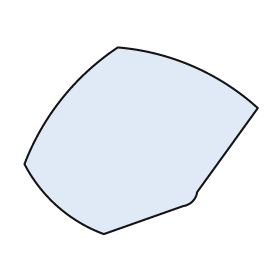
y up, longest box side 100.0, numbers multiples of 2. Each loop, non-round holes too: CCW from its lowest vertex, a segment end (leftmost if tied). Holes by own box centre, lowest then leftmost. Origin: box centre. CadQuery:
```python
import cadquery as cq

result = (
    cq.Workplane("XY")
    .moveTo(-16.0, -40.0)
    .lineTo(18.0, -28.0)
    .threePointArc((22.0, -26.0), (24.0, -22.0))
    .lineTo(50.0, 14.0)
    .threePointArc((22.0, 32.0), (-10.0, 40.0))
    .threePointArc((-34.0, 18.0), (-50.0, -10.0))
    .threePointArc((-36.0, -28.0), (-16.0, -40.0))
    .close()
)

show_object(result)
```